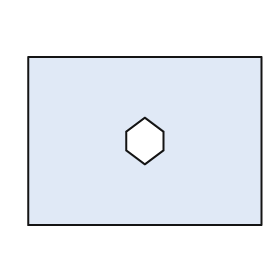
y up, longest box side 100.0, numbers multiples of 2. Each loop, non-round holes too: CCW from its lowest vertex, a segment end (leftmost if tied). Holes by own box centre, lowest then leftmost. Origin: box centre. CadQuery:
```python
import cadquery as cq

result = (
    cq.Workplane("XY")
    .moveTo(-50.0, -36.0)
    .lineTo(50.0, -36.0)
    .lineTo(50.0, 36.0)
    .lineTo(-50.0, 36.0)
    .close()
    .moveTo(0.0, -10.0)
    .lineTo(8.0, -4.0)
    .lineTo(8.0, 4.0)
    .lineTo(0.0, 10.0)
    .lineTo(-8.0, 4.0)
    .lineTo(-8.0, -4.0)
    .close()
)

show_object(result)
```